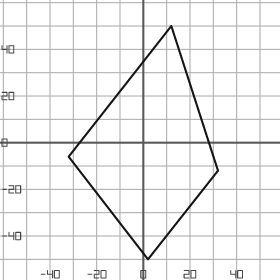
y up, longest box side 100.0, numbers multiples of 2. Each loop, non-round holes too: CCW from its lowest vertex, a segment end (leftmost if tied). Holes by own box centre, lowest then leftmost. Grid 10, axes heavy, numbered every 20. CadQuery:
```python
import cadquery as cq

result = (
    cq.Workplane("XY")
    .moveTo(2.0, -50.0)
    .lineTo(32.0, -12.0)
    .lineTo(12.0, 50.0)
    .lineTo(-32.0, -6.0)
    .close()
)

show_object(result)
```